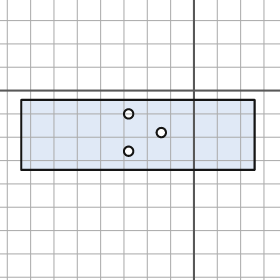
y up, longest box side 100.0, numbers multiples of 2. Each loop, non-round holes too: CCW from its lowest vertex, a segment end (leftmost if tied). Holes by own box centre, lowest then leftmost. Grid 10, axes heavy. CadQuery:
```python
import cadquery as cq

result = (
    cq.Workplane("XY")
    .moveTo(-74.0, -34.0)
    .lineTo(26.0, -34.0)
    .lineTo(26.0, -4.0)
    .lineTo(-74.0, -4.0)
    .close()
    .moveTo(-28.0, -26.0)
    .circle(2.0)
    .moveTo(-14.0, -18.0)
    .circle(2.0)
    .moveTo(-28.0, -10.0)
    .circle(2.0)
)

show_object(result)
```